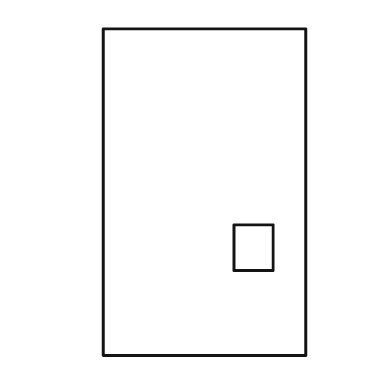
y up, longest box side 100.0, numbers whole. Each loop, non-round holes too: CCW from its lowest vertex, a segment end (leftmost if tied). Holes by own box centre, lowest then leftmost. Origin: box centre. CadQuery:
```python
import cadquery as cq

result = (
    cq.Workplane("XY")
    .moveTo(-31.0, -50.0)
    .lineTo(31.0, -50.0)
    .lineTo(31.0, 50.0)
    .lineTo(-31.0, 50.0)
    .close()
    .moveTo(9.0, -24.0)
    .lineTo(21.0, -24.0)
    .lineTo(21.0, -10.0)
    .lineTo(9.0, -10.0)
    .close()
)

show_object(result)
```